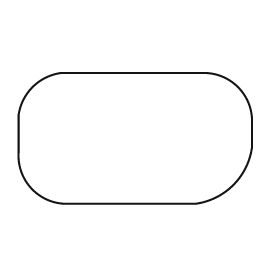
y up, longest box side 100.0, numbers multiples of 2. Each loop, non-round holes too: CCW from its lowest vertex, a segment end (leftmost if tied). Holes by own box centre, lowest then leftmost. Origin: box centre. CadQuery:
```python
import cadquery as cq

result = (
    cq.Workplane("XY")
    .moveTo(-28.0, -28.0)
    .lineTo(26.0, -28.0)
    .threePointArc((42.0, -20.0), (50.0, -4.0))
    .lineTo(50.0, 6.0)
    .threePointArc((44.0, 22.0), (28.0, 28.0))
    .lineTo(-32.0, 28.0)
    .threePointArc((-44.0, 22.0), (-50.0, 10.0))
    .lineTo(-50.0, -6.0)
    .threePointArc((-44.0, -22.0), (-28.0, -28.0))
    .close()
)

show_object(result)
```